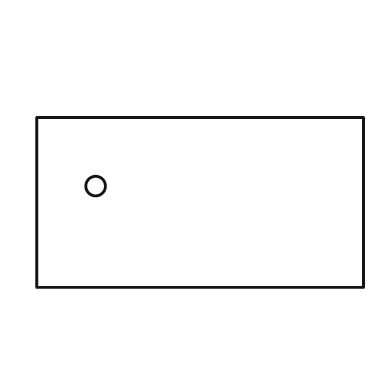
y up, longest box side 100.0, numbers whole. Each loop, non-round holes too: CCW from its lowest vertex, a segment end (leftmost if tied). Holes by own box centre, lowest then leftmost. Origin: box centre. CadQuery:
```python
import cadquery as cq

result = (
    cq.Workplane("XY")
    .moveTo(-50.0, -26.0)
    .lineTo(50.0, -26.0)
    .lineTo(50.0, 26.0)
    .lineTo(-50.0, 26.0)
    .close()
    .moveTo(-32.0, 5.0)
    .circle(3.0)
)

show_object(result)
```